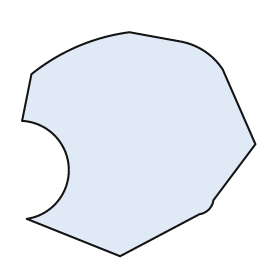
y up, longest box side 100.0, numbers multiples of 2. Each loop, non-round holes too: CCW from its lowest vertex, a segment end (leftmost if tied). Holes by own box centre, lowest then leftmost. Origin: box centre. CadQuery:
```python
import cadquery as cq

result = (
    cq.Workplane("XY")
    .moveTo(-8.0, -48.0)
    .lineTo(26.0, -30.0)
    .threePointArc((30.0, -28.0), (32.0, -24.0))
    .lineTo(50.0, 0.0)
    .lineTo(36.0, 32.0)
    .threePointArc((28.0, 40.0), (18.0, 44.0))
    .lineTo(-4.0, 48.0)
    .threePointArc((-26.0, 42.0), (-46.0, 30.0))
    .lineTo(-50.0, 10.0)
    .threePointArc((-30.0, -10.0), (-48.0, -32.0))
    .close()
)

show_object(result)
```